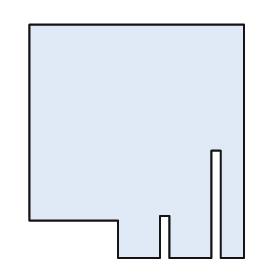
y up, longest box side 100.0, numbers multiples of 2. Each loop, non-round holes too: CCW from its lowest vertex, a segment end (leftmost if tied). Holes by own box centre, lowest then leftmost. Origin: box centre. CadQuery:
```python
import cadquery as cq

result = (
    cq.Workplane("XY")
    .moveTo(-8.0, -50.0)
    .lineTo(10.0, -50.0)
    .lineTo(10.0, -32.0)
    .lineTo(14.0, -32.0)
    .lineTo(14.0, -50.0)
    .lineTo(32.0, -50.0)
    .lineTo(32.0, -4.0)
    .lineTo(36.0, -4.0)
    .lineTo(36.0, -50.0)
    .lineTo(46.0, -50.0)
    .lineTo(46.0, 50.0)
    .lineTo(-46.0, 50.0)
    .lineTo(-46.0, -34.0)
    .lineTo(-8.0, -34.0)
    .close()
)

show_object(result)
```